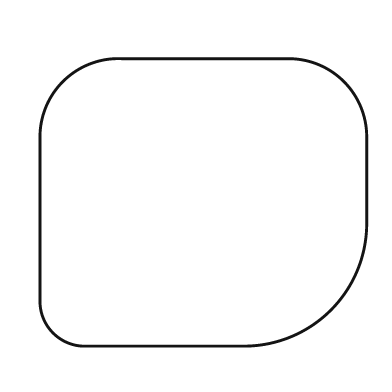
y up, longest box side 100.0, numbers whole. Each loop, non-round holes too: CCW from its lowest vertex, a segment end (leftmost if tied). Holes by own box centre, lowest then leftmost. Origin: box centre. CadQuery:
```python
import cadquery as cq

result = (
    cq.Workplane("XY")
    .moveTo(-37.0, -44.0)
    .lineTo(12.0, -44.0)
    .threePointArc((39.0, -33.0), (50.0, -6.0))
    .lineTo(50.0, 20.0)
    .threePointArc((43.0, 37.0), (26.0, 44.0))
    .lineTo(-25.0, 44.0)
    .threePointArc((-43.0, 37.0), (-50.0, 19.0))
    .lineTo(-50.0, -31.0)
    .threePointArc((-46.0, -40.0), (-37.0, -44.0))
    .close()
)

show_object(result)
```